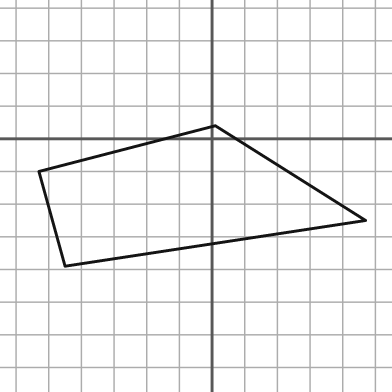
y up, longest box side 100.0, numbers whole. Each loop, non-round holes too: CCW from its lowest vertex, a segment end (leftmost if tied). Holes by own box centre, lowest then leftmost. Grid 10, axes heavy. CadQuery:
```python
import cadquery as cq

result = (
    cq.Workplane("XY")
    .moveTo(-45.0, -39.0)
    .lineTo(47.0, -25.0)
    .lineTo(1.0, 4.0)
    .lineTo(-53.0, -10.0)
    .close()
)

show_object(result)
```